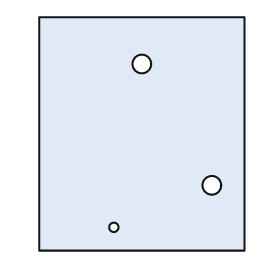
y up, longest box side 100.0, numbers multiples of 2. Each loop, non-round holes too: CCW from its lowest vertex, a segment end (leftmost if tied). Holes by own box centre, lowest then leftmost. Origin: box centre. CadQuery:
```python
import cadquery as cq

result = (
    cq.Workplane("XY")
    .moveTo(-44.0, -50.0)
    .lineTo(44.0, -50.0)
    .lineTo(44.0, 50.0)
    .lineTo(-44.0, 50.0)
    .close()
    .moveTo(-12.0, -40.0)
    .circle(2.0)
    .moveTo(30.0, -22.0)
    .circle(4.0)
    .moveTo(0.0, 30.0)
    .circle(4.0)
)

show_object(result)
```